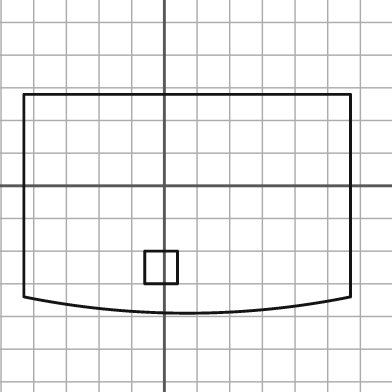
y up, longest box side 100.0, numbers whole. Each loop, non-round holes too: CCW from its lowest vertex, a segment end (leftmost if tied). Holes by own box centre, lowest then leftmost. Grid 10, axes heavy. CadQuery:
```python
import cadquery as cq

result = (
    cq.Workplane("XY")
    .moveTo(-43.0, -34.0)
    .threePointArc((7.0, -39.0), (57.0, -34.0))
    .lineTo(57.0, 28.0)
    .lineTo(-43.0, 28.0)
    .close()
    .moveTo(-6.0, -30.0)
    .lineTo(4.0, -30.0)
    .lineTo(4.0, -20.0)
    .lineTo(-6.0, -20.0)
    .close()
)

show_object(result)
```